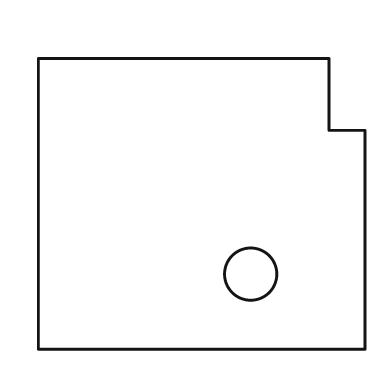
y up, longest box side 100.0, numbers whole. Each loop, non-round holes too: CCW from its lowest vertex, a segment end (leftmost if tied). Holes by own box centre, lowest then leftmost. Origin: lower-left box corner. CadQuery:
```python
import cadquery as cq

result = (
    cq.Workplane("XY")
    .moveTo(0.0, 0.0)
    .lineTo(100.0, 0.0)
    .lineTo(100.0, 67.0)
    .lineTo(89.0, 67.0)
    .lineTo(89.0, 89.0)
    .lineTo(0.0, 89.0)
    .close()
    .moveTo(65.0, 23.0)
    .circle(8.0)
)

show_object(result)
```